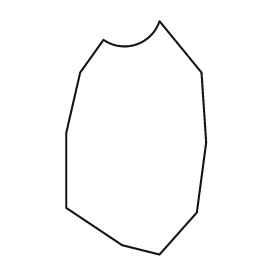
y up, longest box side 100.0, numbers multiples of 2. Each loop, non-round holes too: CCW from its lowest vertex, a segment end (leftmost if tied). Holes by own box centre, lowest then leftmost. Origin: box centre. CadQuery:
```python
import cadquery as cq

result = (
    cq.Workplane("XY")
    .moveTo(10.0, -50.0)
    .lineTo(26.0, -32.0)
    .lineTo(30.0, -2.0)
    .lineTo(28.0, 28.0)
    .lineTo(10.0, 50.0)
    .threePointArc((0.0, 40.0), (-14.0, 42.0))
    .lineTo(-24.0, 28.0)
    .lineTo(-30.0, 2.0)
    .lineTo(-30.0, -30.0)
    .lineTo(-6.0, -46.0)
    .close()
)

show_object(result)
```